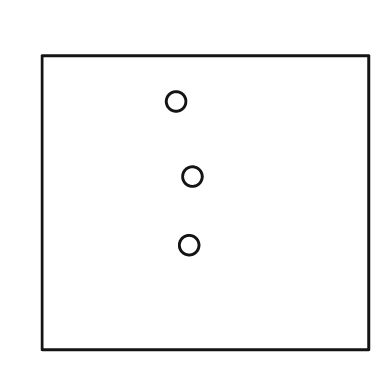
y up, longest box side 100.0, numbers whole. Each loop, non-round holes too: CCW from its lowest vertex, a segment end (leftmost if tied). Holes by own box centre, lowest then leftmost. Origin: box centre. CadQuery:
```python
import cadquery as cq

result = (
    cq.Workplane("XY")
    .moveTo(-50.0, -45.0)
    .lineTo(50.0, -45.0)
    .lineTo(50.0, 45.0)
    .lineTo(-50.0, 45.0)
    .close()
    .moveTo(-5.0, -13.0)
    .circle(3.0)
    .moveTo(-4.0, 8.0)
    .circle(3.0)
    .moveTo(-9.0, 31.0)
    .circle(3.0)
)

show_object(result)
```